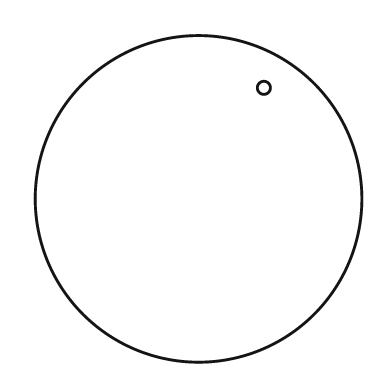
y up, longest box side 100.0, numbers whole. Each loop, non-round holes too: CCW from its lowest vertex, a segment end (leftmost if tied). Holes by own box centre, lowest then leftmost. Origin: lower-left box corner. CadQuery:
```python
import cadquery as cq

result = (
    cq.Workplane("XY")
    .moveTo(50.0, 50.0)
    .circle(50.0)
    .moveTo(70.0, 84.0)
    .circle(2.0)
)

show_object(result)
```